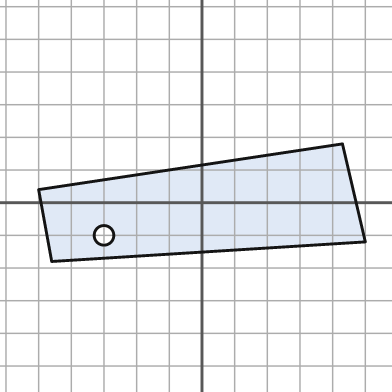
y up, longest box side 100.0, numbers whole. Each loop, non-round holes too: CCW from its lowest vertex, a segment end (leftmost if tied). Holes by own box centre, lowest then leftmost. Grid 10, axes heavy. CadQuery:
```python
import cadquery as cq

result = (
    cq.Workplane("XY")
    .moveTo(-46.0, -18.0)
    .lineTo(50.0, -12.0)
    .lineTo(43.0, 18.0)
    .lineTo(-50.0, 4.0)
    .close()
    .moveTo(-30.0, -10.0)
    .circle(3.0)
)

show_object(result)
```